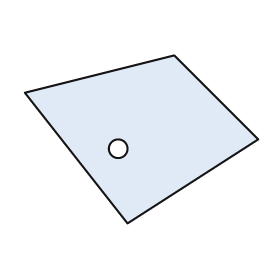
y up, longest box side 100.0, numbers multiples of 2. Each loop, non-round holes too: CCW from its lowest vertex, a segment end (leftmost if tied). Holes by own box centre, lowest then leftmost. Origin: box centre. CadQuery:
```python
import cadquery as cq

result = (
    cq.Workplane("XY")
    .moveTo(-6.0, -36.0)
    .lineTo(50.0, 0.0)
    .lineTo(14.0, 36.0)
    .lineTo(-50.0, 20.0)
    .close()
    .moveTo(-10.0, -4.0)
    .circle(4.0)
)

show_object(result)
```